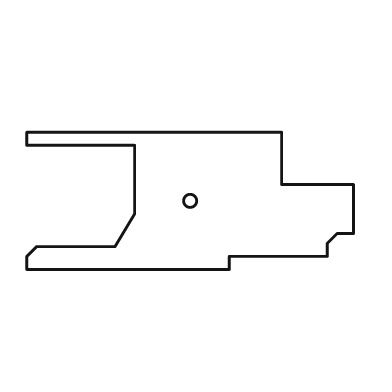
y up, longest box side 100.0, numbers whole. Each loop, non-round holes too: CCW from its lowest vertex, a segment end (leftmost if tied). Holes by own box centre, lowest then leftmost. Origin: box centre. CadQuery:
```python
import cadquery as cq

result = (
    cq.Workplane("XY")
    .moveTo(-50.0, -21.0)
    .lineTo(12.0, -21.0)
    .lineTo(12.0, -17.0)
    .lineTo(42.0, -17.0)
    .lineTo(42.0, -13.0)
    .lineTo(45.0, -10.0)
    .lineTo(50.0, -10.0)
    .lineTo(50.0, 5.0)
    .lineTo(28.0, 5.0)
    .lineTo(28.0, 21.0)
    .lineTo(-50.0, 21.0)
    .lineTo(-50.0, 17.0)
    .lineTo(-17.0, 17.0)
    .lineTo(-17.0, -4.0)
    .lineTo(-23.0, -14.0)
    .lineTo(-47.0, -14.0)
    .lineTo(-50.0, -17.0)
    .close()
    .moveTo(0.0, 0.0)
    .circle(2.0)
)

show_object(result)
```